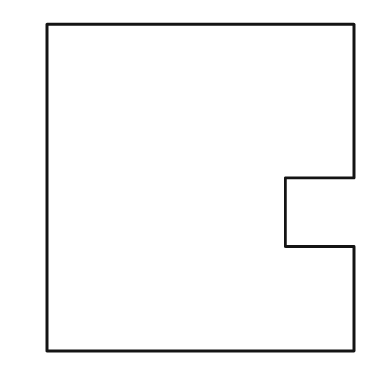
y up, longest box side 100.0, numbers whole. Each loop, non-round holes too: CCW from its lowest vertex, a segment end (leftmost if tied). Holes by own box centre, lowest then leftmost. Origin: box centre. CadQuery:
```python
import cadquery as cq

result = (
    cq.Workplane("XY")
    .moveTo(-47.0, -50.0)
    .lineTo(47.0, -50.0)
    .lineTo(47.0, -18.0)
    .lineTo(26.0, -18.0)
    .lineTo(26.0, 3.0)
    .lineTo(47.0, 3.0)
    .lineTo(47.0, 50.0)
    .lineTo(-47.0, 50.0)
    .close()
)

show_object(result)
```